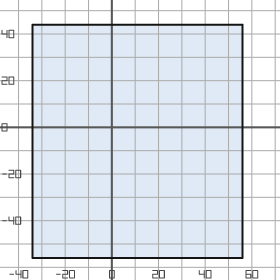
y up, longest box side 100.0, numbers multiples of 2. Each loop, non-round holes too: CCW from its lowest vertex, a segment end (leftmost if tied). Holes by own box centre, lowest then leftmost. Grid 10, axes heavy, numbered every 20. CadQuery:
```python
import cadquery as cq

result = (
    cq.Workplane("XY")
    .moveTo(-34.0, -56.0)
    .lineTo(56.0, -56.0)
    .lineTo(56.0, 44.0)
    .lineTo(-34.0, 44.0)
    .close()
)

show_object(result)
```